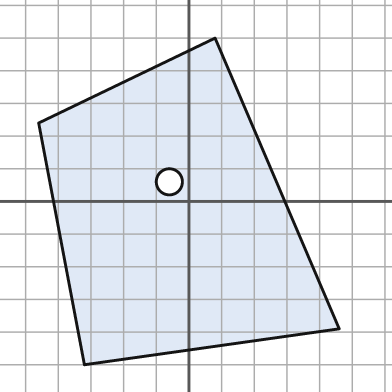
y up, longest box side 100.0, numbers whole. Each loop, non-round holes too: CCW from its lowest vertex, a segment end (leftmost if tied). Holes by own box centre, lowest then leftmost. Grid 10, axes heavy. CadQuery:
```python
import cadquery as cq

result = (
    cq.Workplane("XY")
    .moveTo(-32.0, -50.0)
    .lineTo(46.0, -39.0)
    .lineTo(8.0, 50.0)
    .lineTo(-46.0, 24.0)
    .close()
    .moveTo(-6.0, 6.0)
    .circle(4.0)
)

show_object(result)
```